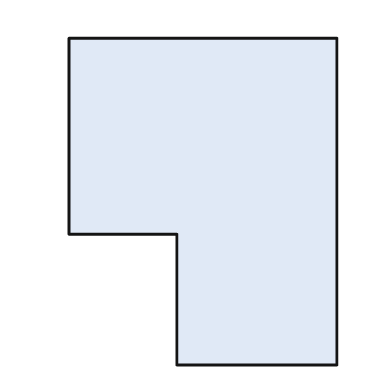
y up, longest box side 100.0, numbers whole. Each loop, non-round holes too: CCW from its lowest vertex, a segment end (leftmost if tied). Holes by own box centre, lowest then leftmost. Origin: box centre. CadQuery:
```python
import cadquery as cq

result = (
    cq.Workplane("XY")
    .moveTo(-8.0, -50.0)
    .lineTo(41.0, -50.0)
    .lineTo(41.0, 50.0)
    .lineTo(-41.0, 50.0)
    .lineTo(-41.0, -10.0)
    .lineTo(-8.0, -10.0)
    .close()
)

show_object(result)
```